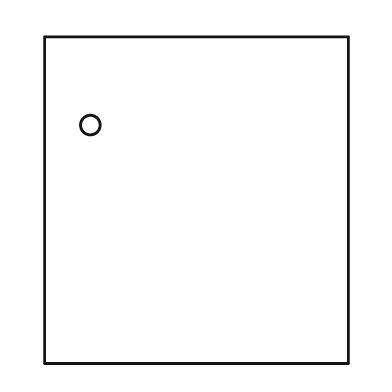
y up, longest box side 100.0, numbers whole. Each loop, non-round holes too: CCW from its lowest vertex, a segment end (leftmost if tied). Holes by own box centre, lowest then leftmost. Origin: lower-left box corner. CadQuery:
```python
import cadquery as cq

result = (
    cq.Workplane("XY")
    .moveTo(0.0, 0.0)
    .lineTo(93.0, 0.0)
    .lineTo(93.0, 100.0)
    .lineTo(0.0, 100.0)
    .close()
    .moveTo(14.0, 73.0)
    .circle(3.0)
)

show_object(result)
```